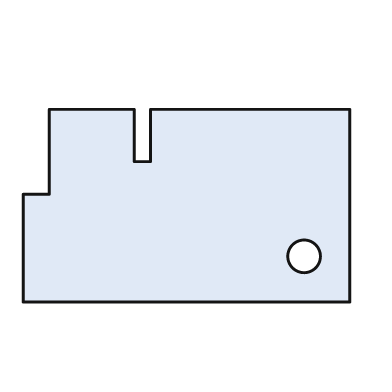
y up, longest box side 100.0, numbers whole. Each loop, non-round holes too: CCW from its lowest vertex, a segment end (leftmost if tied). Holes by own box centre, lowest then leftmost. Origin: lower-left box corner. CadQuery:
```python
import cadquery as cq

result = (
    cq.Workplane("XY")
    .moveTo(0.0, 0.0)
    .lineTo(100.0, 0.0)
    .lineTo(100.0, 59.0)
    .lineTo(39.0, 59.0)
    .lineTo(39.0, 43.0)
    .lineTo(34.0, 43.0)
    .lineTo(34.0, 59.0)
    .lineTo(8.0, 59.0)
    .lineTo(8.0, 33.0)
    .lineTo(0.0, 33.0)
    .close()
    .moveTo(86.0, 14.0)
    .circle(5.0)
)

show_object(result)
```